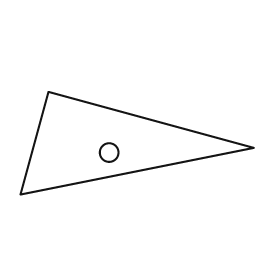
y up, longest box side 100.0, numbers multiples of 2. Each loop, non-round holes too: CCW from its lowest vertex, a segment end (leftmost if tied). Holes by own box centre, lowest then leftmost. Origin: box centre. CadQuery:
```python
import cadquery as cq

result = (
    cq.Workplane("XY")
    .moveTo(-50.0, -22.0)
    .lineTo(50.0, -2.0)
    .lineTo(-38.0, 22.0)
    .close()
    .moveTo(-12.0, -4.0)
    .circle(4.0)
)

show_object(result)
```